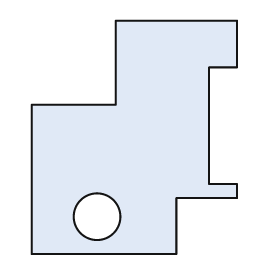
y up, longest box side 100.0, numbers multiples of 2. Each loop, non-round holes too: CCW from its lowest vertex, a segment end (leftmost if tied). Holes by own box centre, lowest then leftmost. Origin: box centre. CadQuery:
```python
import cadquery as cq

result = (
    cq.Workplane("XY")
    .moveTo(-44.0, -50.0)
    .lineTo(18.0, -50.0)
    .lineTo(18.0, -26.0)
    .lineTo(44.0, -26.0)
    .lineTo(44.0, -20.0)
    .lineTo(32.0, -20.0)
    .lineTo(32.0, 30.0)
    .lineTo(44.0, 30.0)
    .lineTo(44.0, 50.0)
    .lineTo(-8.0, 50.0)
    .lineTo(-8.0, 14.0)
    .lineTo(-44.0, 14.0)
    .close()
    .moveTo(-16.0, -34.0)
    .circle(10.0)
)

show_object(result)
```